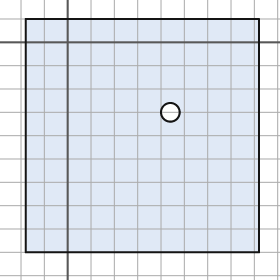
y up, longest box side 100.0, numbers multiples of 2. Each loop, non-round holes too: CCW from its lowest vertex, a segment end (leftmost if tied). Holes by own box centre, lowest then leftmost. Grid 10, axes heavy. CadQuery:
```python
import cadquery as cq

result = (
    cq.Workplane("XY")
    .moveTo(-18.0, -90.0)
    .lineTo(82.0, -90.0)
    .lineTo(82.0, 10.0)
    .lineTo(-18.0, 10.0)
    .close()
    .moveTo(44.0, -30.0)
    .circle(4.0)
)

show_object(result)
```